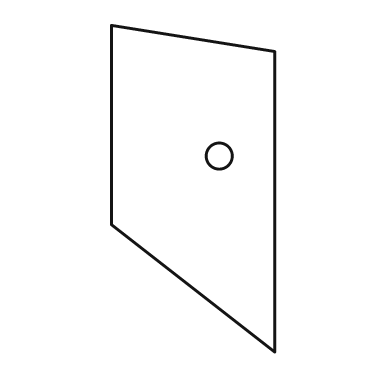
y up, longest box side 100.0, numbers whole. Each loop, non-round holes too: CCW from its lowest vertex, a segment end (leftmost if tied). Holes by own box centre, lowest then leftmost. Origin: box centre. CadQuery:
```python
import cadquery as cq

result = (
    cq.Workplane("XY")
    .moveTo(25.0, -50.0)
    .lineTo(25.0, 42.0)
    .lineTo(-25.0, 50.0)
    .lineTo(-25.0, -11.0)
    .close()
    .moveTo(8.0, 10.0)
    .circle(4.0)
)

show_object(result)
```